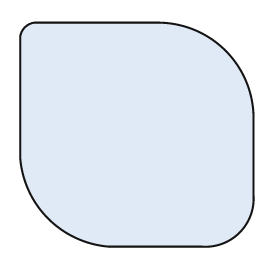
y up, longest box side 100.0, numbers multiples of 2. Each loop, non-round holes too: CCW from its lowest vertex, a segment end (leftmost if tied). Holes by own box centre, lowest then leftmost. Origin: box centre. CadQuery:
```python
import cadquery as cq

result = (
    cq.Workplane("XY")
    .moveTo(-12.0, -48.0)
    .lineTo(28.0, -48.0)
    .threePointArc((44.0, -42.0), (50.0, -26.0))
    .lineTo(50.0, 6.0)
    .threePointArc((38.0, 36.0), (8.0, 48.0))
    .lineTo(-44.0, 48.0)
    .threePointArc((-48.0, 46.0), (-50.0, 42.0))
    .lineTo(-50.0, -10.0)
    .threePointArc((-38.0, -36.0), (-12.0, -48.0))
    .close()
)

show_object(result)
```